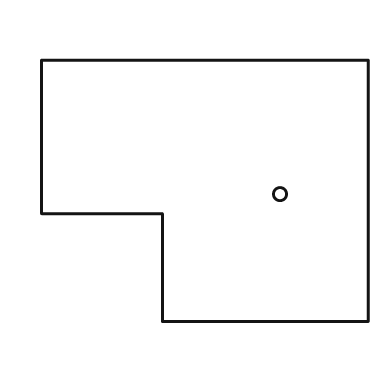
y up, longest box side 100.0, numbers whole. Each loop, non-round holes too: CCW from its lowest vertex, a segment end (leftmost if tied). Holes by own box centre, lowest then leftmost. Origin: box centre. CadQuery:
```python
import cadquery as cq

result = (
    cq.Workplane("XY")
    .moveTo(-13.0, -40.0)
    .lineTo(50.0, -40.0)
    .lineTo(50.0, 40.0)
    .lineTo(-50.0, 40.0)
    .lineTo(-50.0, -7.0)
    .lineTo(-13.0, -7.0)
    .close()
    .moveTo(23.0, -1.0)
    .circle(2.0)
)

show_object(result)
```